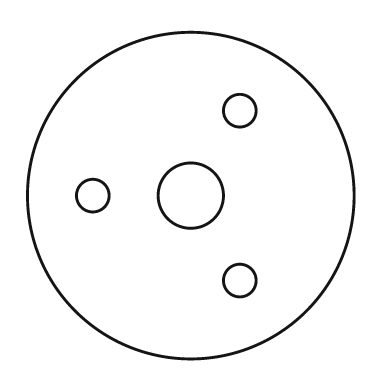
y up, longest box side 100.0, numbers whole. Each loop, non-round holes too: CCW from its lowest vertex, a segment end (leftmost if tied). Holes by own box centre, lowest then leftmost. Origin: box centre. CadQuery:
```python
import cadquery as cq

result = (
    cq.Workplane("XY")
    .moveTo(0.0, 0.0)
    .circle(50.0)
    .moveTo(15.0, -26.0)
    .circle(5.0)
    .moveTo(-30.0, 0.0)
    .circle(5.0)
    .moveTo(0.0, 0.0)
    .circle(10.0)
    .moveTo(15.0, 26.0)
    .circle(5.0)
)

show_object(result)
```